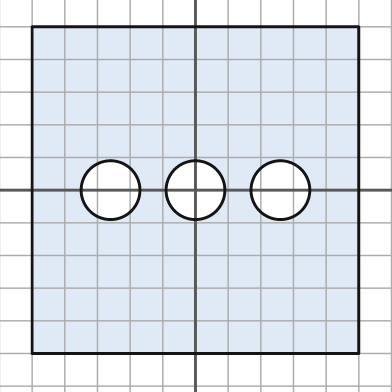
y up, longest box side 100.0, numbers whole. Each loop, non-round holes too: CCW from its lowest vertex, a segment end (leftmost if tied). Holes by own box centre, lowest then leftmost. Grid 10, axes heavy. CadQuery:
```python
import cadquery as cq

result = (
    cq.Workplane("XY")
    .moveTo(-50.0, -50.0)
    .lineTo(50.0, -50.0)
    .lineTo(50.0, 50.0)
    .lineTo(-50.0, 50.0)
    .close()
    .moveTo(-26.0, 0.0)
    .circle(9.0)
    .moveTo(0.0, 0.0)
    .circle(9.0)
    .moveTo(26.0, 0.0)
    .circle(9.0)
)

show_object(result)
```